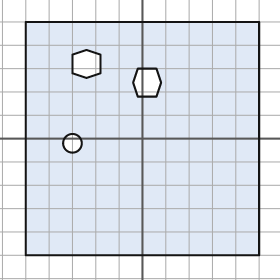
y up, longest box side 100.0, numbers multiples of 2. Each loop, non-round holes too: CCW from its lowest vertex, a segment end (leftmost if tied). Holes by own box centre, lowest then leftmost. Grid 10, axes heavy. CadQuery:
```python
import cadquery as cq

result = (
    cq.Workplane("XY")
    .moveTo(-50.0, -50.0)
    .lineTo(50.0, -50.0)
    .lineTo(50.0, 50.0)
    .lineTo(-50.0, 50.0)
    .close()
    .moveTo(-30.0, -2.0)
    .circle(4.0)
    .moveTo(-2.0, 18.0)
    .lineTo(6.0, 18.0)
    .lineTo(8.0, 24.0)
    .lineTo(6.0, 30.0)
    .lineTo(-2.0, 30.0)
    .lineTo(-4.0, 24.0)
    .close()
    .moveTo(-24.0, 26.0)
    .lineTo(-18.0, 28.0)
    .lineTo(-18.0, 36.0)
    .lineTo(-24.0, 38.0)
    .lineTo(-30.0, 36.0)
    .lineTo(-30.0, 28.0)
    .close()
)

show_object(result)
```